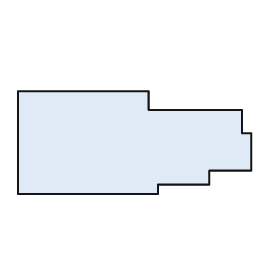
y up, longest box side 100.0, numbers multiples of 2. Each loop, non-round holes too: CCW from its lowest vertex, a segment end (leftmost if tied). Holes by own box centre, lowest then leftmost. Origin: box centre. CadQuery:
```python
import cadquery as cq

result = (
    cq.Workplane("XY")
    .moveTo(-50.0, -22.0)
    .lineTo(10.0, -22.0)
    .lineTo(10.0, -18.0)
    .lineTo(32.0, -18.0)
    .lineTo(32.0, -12.0)
    .lineTo(50.0, -12.0)
    .lineTo(50.0, 4.0)
    .lineTo(46.0, 4.0)
    .lineTo(46.0, 14.0)
    .lineTo(6.0, 14.0)
    .lineTo(6.0, 22.0)
    .lineTo(-50.0, 22.0)
    .close()
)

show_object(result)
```